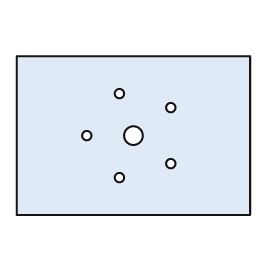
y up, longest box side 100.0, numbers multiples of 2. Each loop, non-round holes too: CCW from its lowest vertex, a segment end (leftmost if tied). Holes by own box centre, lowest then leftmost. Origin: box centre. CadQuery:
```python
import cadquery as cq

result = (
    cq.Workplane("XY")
    .moveTo(-50.0, -34.0)
    .lineTo(50.0, -34.0)
    .lineTo(50.0, 34.0)
    .lineTo(-50.0, 34.0)
    .close()
    .moveTo(-6.0, -18.0)
    .circle(2.0)
    .moveTo(16.0, -12.0)
    .circle(2.0)
    .moveTo(-20.0, 0.0)
    .circle(2.0)
    .moveTo(0.0, 0.0)
    .circle(4.0)
    .moveTo(16.0, 12.0)
    .circle(2.0)
    .moveTo(-6.0, 18.0)
    .circle(2.0)
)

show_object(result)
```